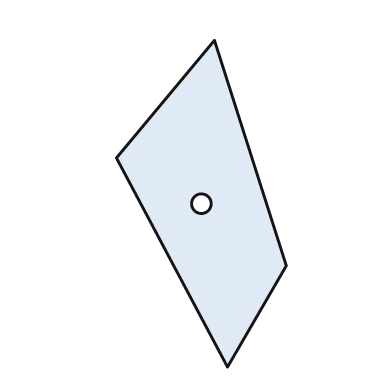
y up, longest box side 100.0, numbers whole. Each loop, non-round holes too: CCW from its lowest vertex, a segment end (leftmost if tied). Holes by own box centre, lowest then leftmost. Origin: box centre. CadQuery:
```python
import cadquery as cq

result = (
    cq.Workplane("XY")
    .moveTo(8.0, -50.0)
    .lineTo(26.0, -19.0)
    .lineTo(4.0, 50.0)
    .lineTo(-26.0, 14.0)
    .close()
    .moveTo(0.0, 0.0)
    .circle(3.0)
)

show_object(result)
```